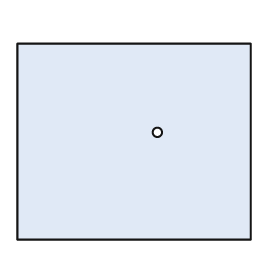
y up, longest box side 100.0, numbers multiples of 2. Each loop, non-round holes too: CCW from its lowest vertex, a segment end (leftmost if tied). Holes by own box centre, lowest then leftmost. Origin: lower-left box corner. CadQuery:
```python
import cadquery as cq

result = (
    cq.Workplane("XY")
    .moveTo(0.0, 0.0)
    .lineTo(100.0, 0.0)
    .lineTo(100.0, 84.0)
    .lineTo(0.0, 84.0)
    .close()
    .moveTo(60.0, 46.0)
    .circle(2.0)
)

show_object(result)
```